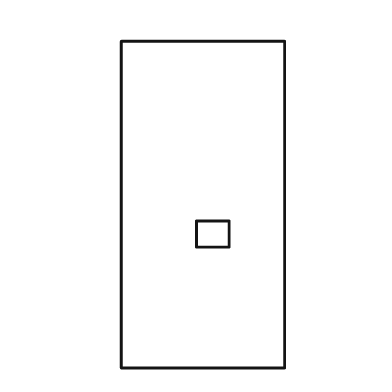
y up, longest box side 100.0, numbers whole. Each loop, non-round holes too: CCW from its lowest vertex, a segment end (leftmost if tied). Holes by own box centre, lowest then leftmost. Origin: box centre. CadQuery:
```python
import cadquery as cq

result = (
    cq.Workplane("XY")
    .moveTo(-25.0, -50.0)
    .lineTo(25.0, -50.0)
    .lineTo(25.0, 50.0)
    .lineTo(-25.0, 50.0)
    .close()
    .moveTo(-2.0, -13.0)
    .lineTo(8.0, -13.0)
    .lineTo(8.0, -5.0)
    .lineTo(-2.0, -5.0)
    .close()
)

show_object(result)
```